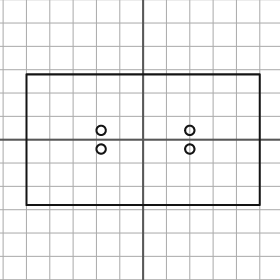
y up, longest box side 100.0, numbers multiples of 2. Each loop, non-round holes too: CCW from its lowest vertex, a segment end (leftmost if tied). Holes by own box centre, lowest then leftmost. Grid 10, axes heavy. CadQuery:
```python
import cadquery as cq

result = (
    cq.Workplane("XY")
    .moveTo(-50.0, -28.0)
    .lineTo(50.0, -28.0)
    .lineTo(50.0, 28.0)
    .lineTo(-50.0, 28.0)
    .close()
    .moveTo(-18.0, -4.0)
    .circle(2.0)
    .moveTo(20.0, -4.0)
    .circle(2.0)
    .moveTo(-18.0, 4.0)
    .circle(2.0)
    .moveTo(20.0, 4.0)
    .circle(2.0)
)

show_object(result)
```